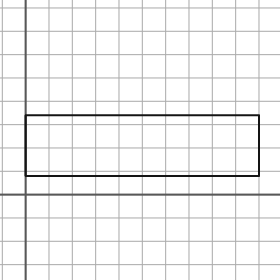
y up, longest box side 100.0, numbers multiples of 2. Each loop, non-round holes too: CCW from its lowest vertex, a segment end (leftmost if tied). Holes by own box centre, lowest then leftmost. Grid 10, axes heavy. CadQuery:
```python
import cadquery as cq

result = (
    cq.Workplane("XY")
    .moveTo(0.0, 8.0)
    .lineTo(100.0, 8.0)
    .lineTo(100.0, 34.0)
    .lineTo(0.0, 34.0)
    .close()
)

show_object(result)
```